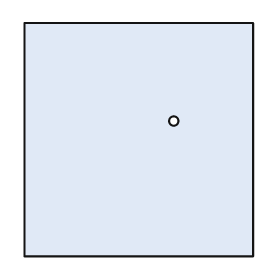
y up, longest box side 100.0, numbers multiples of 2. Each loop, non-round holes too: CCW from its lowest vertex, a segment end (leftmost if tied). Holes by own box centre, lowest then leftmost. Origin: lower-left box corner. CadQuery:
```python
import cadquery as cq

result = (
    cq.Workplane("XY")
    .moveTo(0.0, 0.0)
    .lineTo(98.0, 0.0)
    .lineTo(98.0, 100.0)
    .lineTo(0.0, 100.0)
    .close()
    .moveTo(64.0, 58.0)
    .circle(2.0)
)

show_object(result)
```